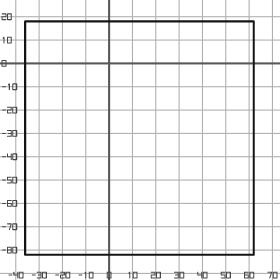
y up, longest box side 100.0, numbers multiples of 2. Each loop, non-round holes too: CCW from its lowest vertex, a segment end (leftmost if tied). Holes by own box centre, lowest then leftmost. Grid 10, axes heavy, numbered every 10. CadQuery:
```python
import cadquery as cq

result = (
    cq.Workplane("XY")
    .moveTo(-36.0, -82.0)
    .lineTo(62.0, -82.0)
    .lineTo(62.0, 18.0)
    .lineTo(-36.0, 18.0)
    .close()
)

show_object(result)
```